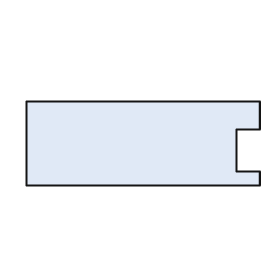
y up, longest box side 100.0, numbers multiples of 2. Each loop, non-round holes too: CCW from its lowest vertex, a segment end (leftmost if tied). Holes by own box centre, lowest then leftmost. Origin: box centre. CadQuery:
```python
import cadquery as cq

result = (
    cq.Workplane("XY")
    .moveTo(-50.0, -18.0)
    .lineTo(50.0, -18.0)
    .lineTo(50.0, -12.0)
    .lineTo(40.0, -12.0)
    .lineTo(40.0, 6.0)
    .lineTo(50.0, 6.0)
    .lineTo(50.0, 18.0)
    .lineTo(-50.0, 18.0)
    .close()
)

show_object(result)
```